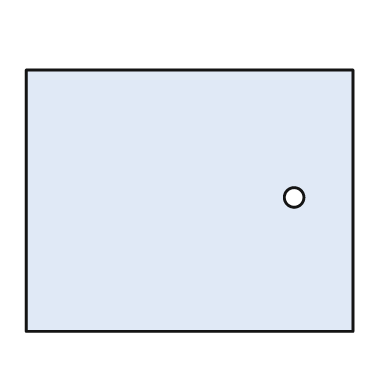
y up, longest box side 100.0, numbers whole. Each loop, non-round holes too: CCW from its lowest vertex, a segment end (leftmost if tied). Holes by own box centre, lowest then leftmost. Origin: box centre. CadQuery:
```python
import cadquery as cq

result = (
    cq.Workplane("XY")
    .moveTo(-50.0, -40.0)
    .lineTo(50.0, -40.0)
    .lineTo(50.0, 40.0)
    .lineTo(-50.0, 40.0)
    .close()
    .moveTo(32.0, 1.0)
    .circle(3.0)
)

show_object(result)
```